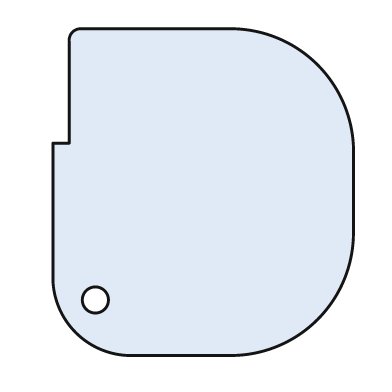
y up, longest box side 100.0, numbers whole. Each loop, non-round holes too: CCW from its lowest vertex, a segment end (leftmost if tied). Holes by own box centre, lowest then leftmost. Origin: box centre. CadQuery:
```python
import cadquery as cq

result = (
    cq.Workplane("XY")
    .moveTo(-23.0, -50.0)
    .lineTo(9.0, -50.0)
    .threePointArc((35.0, -39.0), (46.0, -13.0))
    .lineTo(46.0, 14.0)
    .threePointArc((35.0, 39.0), (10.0, 50.0))
    .lineTo(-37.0, 50.0)
    .threePointArc((-40.0, 49.0), (-41.0, 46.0))
    .lineTo(-41.0, 15.0)
    .lineTo(-46.0, 15.0)
    .lineTo(-46.0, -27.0)
    .threePointArc((-39.0, -43.0), (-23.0, -50.0))
    .close()
    .moveTo(-33.0, -33.0)
    .circle(4.0)
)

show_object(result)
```